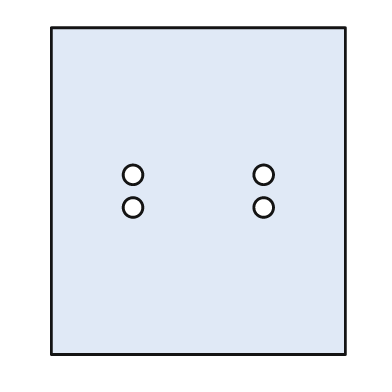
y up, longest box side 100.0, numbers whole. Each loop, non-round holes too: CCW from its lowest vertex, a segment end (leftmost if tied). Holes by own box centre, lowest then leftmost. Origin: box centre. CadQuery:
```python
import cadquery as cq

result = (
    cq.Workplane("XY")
    .moveTo(-45.0, -50.0)
    .lineTo(45.0, -50.0)
    .lineTo(45.0, 50.0)
    .lineTo(-45.0, 50.0)
    .close()
    .moveTo(-20.0, -5.0)
    .circle(3.0)
    .moveTo(20.0, -5.0)
    .circle(3.0)
    .moveTo(-20.0, 5.0)
    .circle(3.0)
    .moveTo(20.0, 5.0)
    .circle(3.0)
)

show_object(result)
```